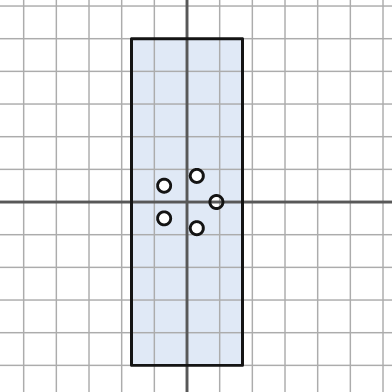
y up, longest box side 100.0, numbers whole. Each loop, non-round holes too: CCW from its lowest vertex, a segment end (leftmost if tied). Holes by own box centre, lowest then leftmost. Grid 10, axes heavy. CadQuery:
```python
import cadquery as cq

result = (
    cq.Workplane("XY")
    .moveTo(-17.0, -50.0)
    .lineTo(17.0, -50.0)
    .lineTo(17.0, 50.0)
    .lineTo(-17.0, 50.0)
    .close()
    .moveTo(3.0, -8.0)
    .circle(2.0)
    .moveTo(-7.0, -5.0)
    .circle(2.0)
    .moveTo(9.0, 0.0)
    .circle(2.0)
    .moveTo(-7.0, 5.0)
    .circle(2.0)
    .moveTo(3.0, 8.0)
    .circle(2.0)
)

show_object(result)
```